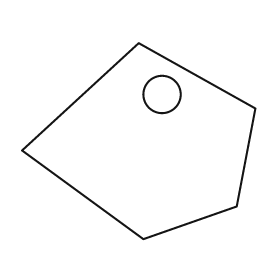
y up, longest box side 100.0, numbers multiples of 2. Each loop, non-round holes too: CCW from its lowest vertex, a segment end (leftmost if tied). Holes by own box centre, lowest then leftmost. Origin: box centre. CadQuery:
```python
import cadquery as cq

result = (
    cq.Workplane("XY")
    .moveTo(2.0, -42.0)
    .lineTo(42.0, -28.0)
    .lineTo(50.0, 14.0)
    .lineTo(0.0, 42.0)
    .lineTo(-50.0, -4.0)
    .close()
    .moveTo(10.0, 20.0)
    .circle(8.0)
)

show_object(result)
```